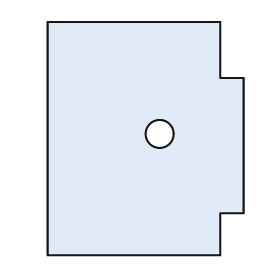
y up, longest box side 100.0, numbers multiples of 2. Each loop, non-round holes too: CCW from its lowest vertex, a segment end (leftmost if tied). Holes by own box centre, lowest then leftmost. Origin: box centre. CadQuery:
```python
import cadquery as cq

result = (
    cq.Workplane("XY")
    .moveTo(-42.0, -50.0)
    .lineTo(32.0, -50.0)
    .lineTo(32.0, -32.0)
    .lineTo(42.0, -32.0)
    .lineTo(42.0, 26.0)
    .lineTo(32.0, 26.0)
    .lineTo(32.0, 50.0)
    .lineTo(-42.0, 50.0)
    .close()
    .moveTo(6.0, 2.0)
    .circle(6.0)
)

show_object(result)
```